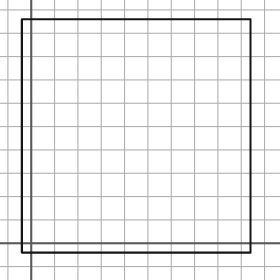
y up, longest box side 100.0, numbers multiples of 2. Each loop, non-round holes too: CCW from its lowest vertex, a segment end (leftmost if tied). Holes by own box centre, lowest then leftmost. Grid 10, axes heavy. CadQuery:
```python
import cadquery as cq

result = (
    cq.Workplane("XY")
    .moveTo(-4.0, -4.0)
    .lineTo(94.0, -4.0)
    .lineTo(94.0, 96.0)
    .lineTo(-4.0, 96.0)
    .close()
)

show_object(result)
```